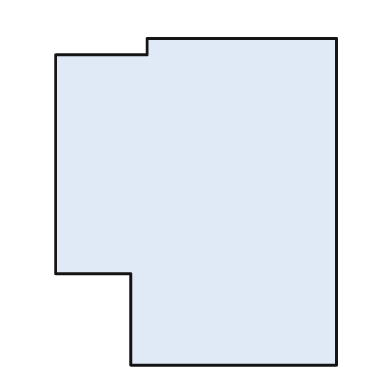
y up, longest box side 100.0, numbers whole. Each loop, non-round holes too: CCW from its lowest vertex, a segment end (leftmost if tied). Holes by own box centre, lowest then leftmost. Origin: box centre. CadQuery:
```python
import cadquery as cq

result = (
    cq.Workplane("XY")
    .moveTo(-20.0, -50.0)
    .lineTo(43.0, -50.0)
    .lineTo(43.0, 50.0)
    .lineTo(-15.0, 50.0)
    .lineTo(-15.0, 45.0)
    .lineTo(-43.0, 45.0)
    .lineTo(-43.0, -22.0)
    .lineTo(-20.0, -22.0)
    .close()
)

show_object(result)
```